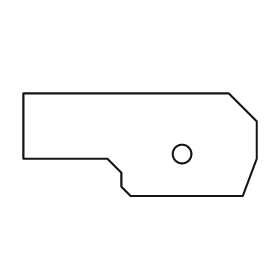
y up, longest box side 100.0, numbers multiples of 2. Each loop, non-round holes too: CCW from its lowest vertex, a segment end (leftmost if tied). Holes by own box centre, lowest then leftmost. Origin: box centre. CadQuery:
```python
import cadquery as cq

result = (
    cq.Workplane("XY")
    .moveTo(-4.0, -22.0)
    .lineTo(44.0, -22.0)
    .lineTo(50.0, -6.0)
    .lineTo(50.0, 10.0)
    .lineTo(38.0, 22.0)
    .lineTo(-50.0, 22.0)
    .lineTo(-50.0, -6.0)
    .lineTo(-14.0, -6.0)
    .lineTo(-8.0, -12.0)
    .lineTo(-8.0, -18.0)
    .close()
    .moveTo(18.0, -4.0)
    .circle(4.0)
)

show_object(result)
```